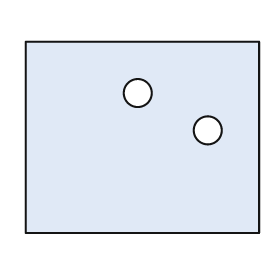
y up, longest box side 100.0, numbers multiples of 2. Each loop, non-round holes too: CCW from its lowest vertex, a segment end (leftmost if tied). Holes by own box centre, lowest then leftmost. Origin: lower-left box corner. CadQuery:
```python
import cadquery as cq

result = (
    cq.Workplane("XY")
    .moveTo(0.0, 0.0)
    .lineTo(100.0, 0.0)
    .lineTo(100.0, 82.0)
    .lineTo(0.0, 82.0)
    .close()
    .moveTo(78.0, 44.0)
    .circle(6.0)
    .moveTo(48.0, 60.0)
    .circle(6.0)
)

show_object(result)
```